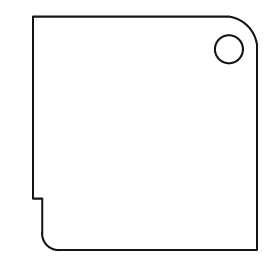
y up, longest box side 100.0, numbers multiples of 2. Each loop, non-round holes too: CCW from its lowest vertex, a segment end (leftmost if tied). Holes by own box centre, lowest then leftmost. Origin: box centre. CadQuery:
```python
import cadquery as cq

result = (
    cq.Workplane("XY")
    .moveTo(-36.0, -50.0)
    .lineTo(48.0, -50.0)
    .lineTo(48.0, 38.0)
    .threePointArc((44.0, 46.0), (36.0, 50.0))
    .lineTo(-48.0, 50.0)
    .lineTo(-48.0, -28.0)
    .lineTo(-44.0, -28.0)
    .lineTo(-44.0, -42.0)
    .threePointArc((-42.0, -48.0), (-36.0, -50.0))
    .close()
    .moveTo(36.0, 36.0)
    .circle(6.0)
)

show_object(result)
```